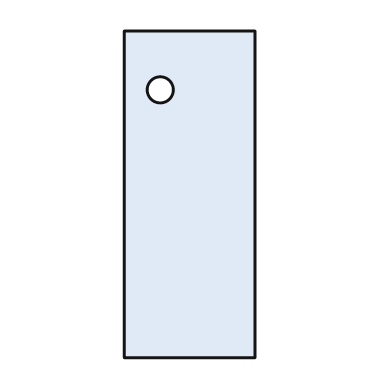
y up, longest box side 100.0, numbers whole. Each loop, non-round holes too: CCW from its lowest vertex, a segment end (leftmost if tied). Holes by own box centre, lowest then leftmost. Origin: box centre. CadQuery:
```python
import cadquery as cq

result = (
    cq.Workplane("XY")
    .moveTo(-20.0, -50.0)
    .lineTo(20.0, -50.0)
    .lineTo(20.0, 50.0)
    .lineTo(-20.0, 50.0)
    .close()
    .moveTo(-9.0, 32.0)
    .circle(4.0)
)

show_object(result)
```